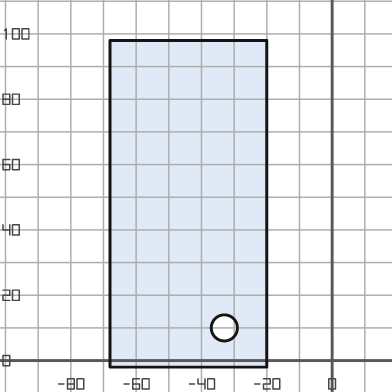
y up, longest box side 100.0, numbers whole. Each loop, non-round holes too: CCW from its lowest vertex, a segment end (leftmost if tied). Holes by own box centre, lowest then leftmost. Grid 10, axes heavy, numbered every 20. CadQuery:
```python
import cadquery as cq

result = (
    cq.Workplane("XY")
    .moveTo(-68.0, -2.0)
    .lineTo(-20.0, -2.0)
    .lineTo(-20.0, 98.0)
    .lineTo(-68.0, 98.0)
    .close()
    .moveTo(-33.0, 10.0)
    .circle(4.0)
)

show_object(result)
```